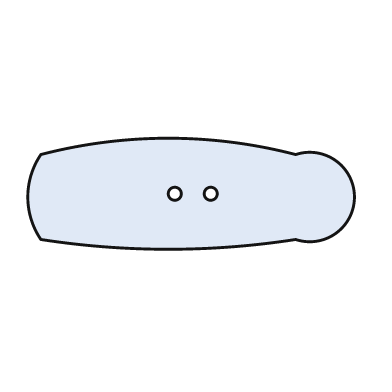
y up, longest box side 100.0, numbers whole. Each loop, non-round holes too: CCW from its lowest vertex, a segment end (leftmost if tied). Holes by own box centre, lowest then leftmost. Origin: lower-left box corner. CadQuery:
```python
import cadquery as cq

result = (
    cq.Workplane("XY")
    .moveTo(4.0, 3.0)
    .threePointArc((43.0, 0.0), (82.0, 3.0))
    .threePointArc((100.0, 16.0), (82.0, 29.0))
    .threePointArc((43.0, 34.0), (4.0, 29.0))
    .threePointArc((0.0, 16.0), (4.0, 3.0))
    .close()
    .moveTo(45.0, 17.0)
    .circle(2.0)
    .moveTo(56.0, 17.0)
    .circle(2.0)
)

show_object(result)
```